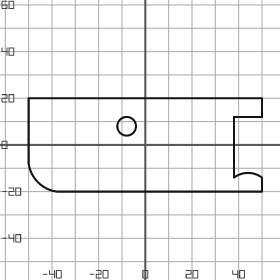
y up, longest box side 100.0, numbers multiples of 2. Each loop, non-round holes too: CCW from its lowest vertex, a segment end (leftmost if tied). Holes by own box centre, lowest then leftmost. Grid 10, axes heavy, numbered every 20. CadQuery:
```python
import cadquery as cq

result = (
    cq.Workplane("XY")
    .moveTo(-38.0, -20.0)
    .lineTo(50.0, -20.0)
    .lineTo(50.0, -14.0)
    .threePointArc((44.0, -12.0), (38.0, -14.0))
    .lineTo(38.0, 12.0)
    .lineTo(50.0, 12.0)
    .lineTo(50.0, 20.0)
    .lineTo(-50.0, 20.0)
    .lineTo(-50.0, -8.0)
    .threePointArc((-46.0, -16.0), (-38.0, -20.0))
    .close()
    .moveTo(-8.0, 8.0)
    .circle(4.0)
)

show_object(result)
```